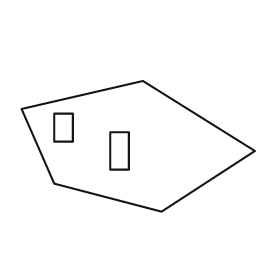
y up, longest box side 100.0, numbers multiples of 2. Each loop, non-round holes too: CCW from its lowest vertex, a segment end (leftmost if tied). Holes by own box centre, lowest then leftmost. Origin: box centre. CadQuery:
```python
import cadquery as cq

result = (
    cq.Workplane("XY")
    .moveTo(10.0, -28.0)
    .lineTo(50.0, -2.0)
    .lineTo(2.0, 28.0)
    .lineTo(-50.0, 16.0)
    .lineTo(-36.0, -16.0)
    .close()
    .moveTo(-12.0, -10.0)
    .lineTo(-4.0, -10.0)
    .lineTo(-4.0, 6.0)
    .lineTo(-12.0, 6.0)
    .close()
    .moveTo(-36.0, 2.0)
    .lineTo(-28.0, 2.0)
    .lineTo(-28.0, 14.0)
    .lineTo(-36.0, 14.0)
    .close()
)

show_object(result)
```